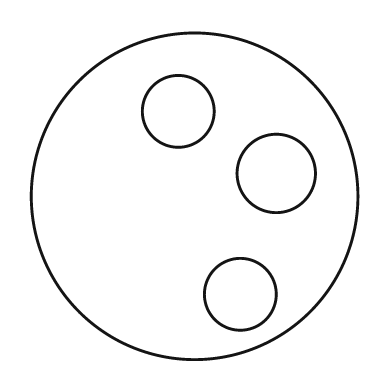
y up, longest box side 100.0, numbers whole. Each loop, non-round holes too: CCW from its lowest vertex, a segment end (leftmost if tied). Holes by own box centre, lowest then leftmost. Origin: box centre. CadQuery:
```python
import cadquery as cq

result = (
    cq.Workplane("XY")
    .moveTo(0.0, 0.0)
    .circle(50.0)
    .moveTo(14.0, -30.0)
    .circle(11.0)
    .moveTo(25.0, 7.0)
    .circle(12.0)
    .moveTo(-5.0, 26.0)
    .circle(11.0)
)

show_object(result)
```